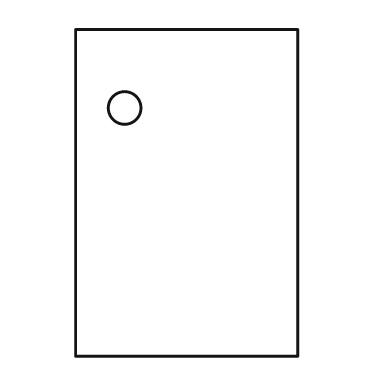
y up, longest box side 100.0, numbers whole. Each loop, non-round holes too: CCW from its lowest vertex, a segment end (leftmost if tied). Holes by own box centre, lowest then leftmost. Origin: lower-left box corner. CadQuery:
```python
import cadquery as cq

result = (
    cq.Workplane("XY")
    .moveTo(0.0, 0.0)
    .lineTo(68.0, 0.0)
    .lineTo(68.0, 100.0)
    .lineTo(0.0, 100.0)
    .close()
    .moveTo(15.0, 76.0)
    .circle(5.0)
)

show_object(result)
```